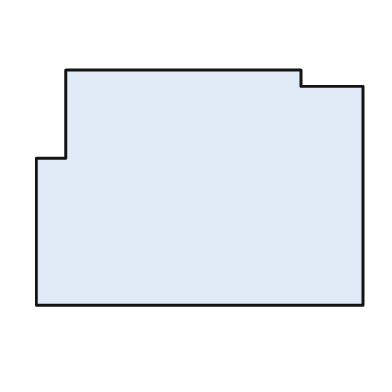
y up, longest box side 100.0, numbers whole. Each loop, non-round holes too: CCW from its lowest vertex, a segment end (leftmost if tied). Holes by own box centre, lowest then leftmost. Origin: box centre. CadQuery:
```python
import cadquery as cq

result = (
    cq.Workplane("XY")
    .moveTo(-50.0, -36.0)
    .lineTo(50.0, -36.0)
    .lineTo(50.0, 31.0)
    .lineTo(31.0, 31.0)
    .lineTo(31.0, 36.0)
    .lineTo(-41.0, 36.0)
    .lineTo(-41.0, 9.0)
    .lineTo(-50.0, 9.0)
    .close()
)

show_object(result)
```